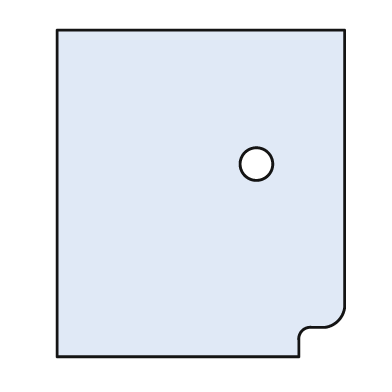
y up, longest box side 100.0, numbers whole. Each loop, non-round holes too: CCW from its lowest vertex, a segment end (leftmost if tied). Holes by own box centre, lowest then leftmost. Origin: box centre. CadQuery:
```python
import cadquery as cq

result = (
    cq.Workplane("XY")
    .moveTo(-44.0, -50.0)
    .lineTo(30.0, -50.0)
    .lineTo(30.0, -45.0)
    .threePointArc((31.0, -42.0), (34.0, -41.0))
    .lineTo(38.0, -41.0)
    .threePointArc((42.0, -39.0), (44.0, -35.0))
    .lineTo(44.0, 50.0)
    .lineTo(-44.0, 50.0)
    .close()
    .moveTo(17.0, 9.0)
    .circle(5.0)
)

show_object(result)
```